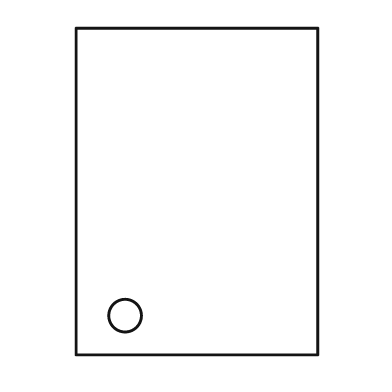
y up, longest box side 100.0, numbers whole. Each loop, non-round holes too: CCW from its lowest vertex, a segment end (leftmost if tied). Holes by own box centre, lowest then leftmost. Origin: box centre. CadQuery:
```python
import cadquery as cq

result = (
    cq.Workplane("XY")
    .moveTo(-37.0, -50.0)
    .lineTo(37.0, -50.0)
    .lineTo(37.0, 50.0)
    .lineTo(-37.0, 50.0)
    .close()
    .moveTo(-22.0, -38.0)
    .circle(5.0)
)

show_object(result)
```